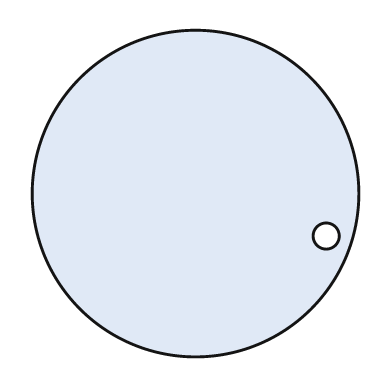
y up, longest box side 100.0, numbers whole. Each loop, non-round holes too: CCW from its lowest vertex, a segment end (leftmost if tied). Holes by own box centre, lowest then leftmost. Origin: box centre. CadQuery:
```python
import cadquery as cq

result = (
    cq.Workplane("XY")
    .moveTo(0.0, 0.0)
    .circle(50.0)
    .moveTo(40.0, -13.0)
    .circle(4.0)
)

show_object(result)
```